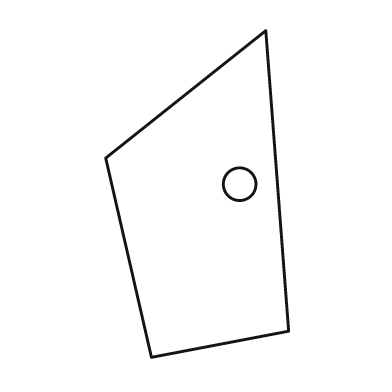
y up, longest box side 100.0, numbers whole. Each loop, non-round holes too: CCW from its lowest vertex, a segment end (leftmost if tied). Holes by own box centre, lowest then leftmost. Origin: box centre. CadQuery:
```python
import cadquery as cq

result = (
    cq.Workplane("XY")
    .moveTo(-14.0, -50.0)
    .lineTo(28.0, -42.0)
    .lineTo(21.0, 50.0)
    .lineTo(-28.0, 11.0)
    .close()
    .moveTo(13.0, 3.0)
    .circle(5.0)
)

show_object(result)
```